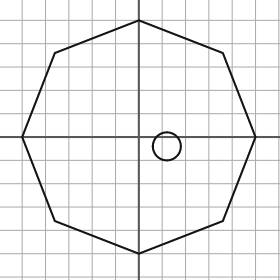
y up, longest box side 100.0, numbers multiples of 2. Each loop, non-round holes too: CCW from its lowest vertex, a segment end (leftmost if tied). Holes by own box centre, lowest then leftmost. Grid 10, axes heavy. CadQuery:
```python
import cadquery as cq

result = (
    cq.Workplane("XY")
    .moveTo(0.0, -50.0)
    .lineTo(36.0, -36.0)
    .lineTo(50.0, 0.0)
    .lineTo(36.0, 36.0)
    .lineTo(0.0, 50.0)
    .lineTo(-36.0, 36.0)
    .lineTo(-50.0, 0.0)
    .lineTo(-36.0, -36.0)
    .close()
    .moveTo(12.0, -4.0)
    .circle(6.0)
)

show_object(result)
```